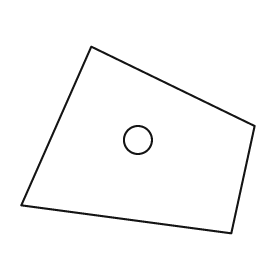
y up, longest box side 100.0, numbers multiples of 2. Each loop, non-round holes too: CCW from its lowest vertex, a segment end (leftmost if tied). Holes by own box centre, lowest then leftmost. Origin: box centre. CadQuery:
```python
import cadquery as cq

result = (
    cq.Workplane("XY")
    .moveTo(40.0, -40.0)
    .lineTo(50.0, 6.0)
    .lineTo(-20.0, 40.0)
    .lineTo(-50.0, -28.0)
    .close()
    .moveTo(0.0, 0.0)
    .circle(6.0)
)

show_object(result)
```